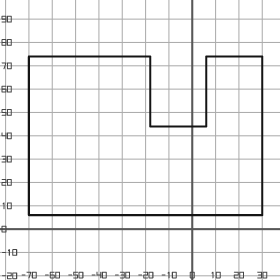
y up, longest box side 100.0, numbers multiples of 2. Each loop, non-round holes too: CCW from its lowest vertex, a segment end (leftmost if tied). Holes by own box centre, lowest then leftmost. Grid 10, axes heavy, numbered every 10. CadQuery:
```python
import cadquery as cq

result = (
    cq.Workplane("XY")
    .moveTo(-70.0, 6.0)
    .lineTo(30.0, 6.0)
    .lineTo(30.0, 74.0)
    .lineTo(6.0, 74.0)
    .lineTo(6.0, 44.0)
    .lineTo(-18.0, 44.0)
    .lineTo(-18.0, 74.0)
    .lineTo(-70.0, 74.0)
    .close()
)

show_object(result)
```